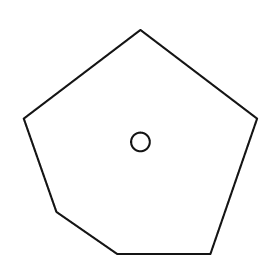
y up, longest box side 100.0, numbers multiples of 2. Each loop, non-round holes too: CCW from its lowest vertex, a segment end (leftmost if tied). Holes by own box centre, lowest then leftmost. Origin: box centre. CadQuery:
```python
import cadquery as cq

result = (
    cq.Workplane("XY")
    .moveTo(-10.0, -48.0)
    .lineTo(30.0, -48.0)
    .lineTo(50.0, 10.0)
    .lineTo(0.0, 48.0)
    .lineTo(-50.0, 10.0)
    .lineTo(-36.0, -30.0)
    .close()
    .moveTo(0.0, 0.0)
    .circle(4.0)
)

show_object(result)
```